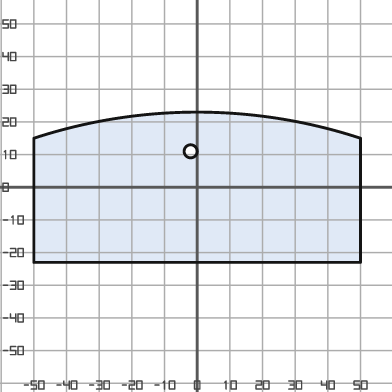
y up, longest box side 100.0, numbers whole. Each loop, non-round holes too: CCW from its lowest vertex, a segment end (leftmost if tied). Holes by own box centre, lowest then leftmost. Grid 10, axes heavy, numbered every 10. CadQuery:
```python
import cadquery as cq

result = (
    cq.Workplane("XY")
    .moveTo(-50.0, -23.0)
    .lineTo(50.0, -23.0)
    .lineTo(50.0, 15.0)
    .threePointArc((0.0, 23.0), (-50.0, 15.0))
    .close()
    .moveTo(-2.0, 11.0)
    .circle(2.0)
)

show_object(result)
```